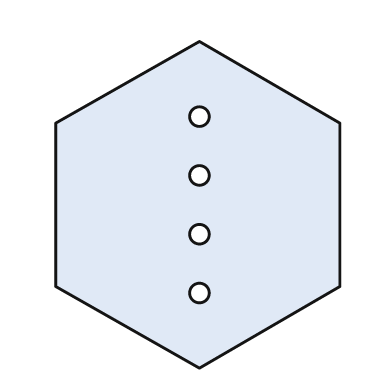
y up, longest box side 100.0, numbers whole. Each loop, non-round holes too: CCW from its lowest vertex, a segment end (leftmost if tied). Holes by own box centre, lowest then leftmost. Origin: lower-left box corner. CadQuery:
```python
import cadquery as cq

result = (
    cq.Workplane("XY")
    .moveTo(44.0, 0.0)
    .lineTo(87.0, 25.0)
    .lineTo(87.0, 75.0)
    .lineTo(44.0, 100.0)
    .lineTo(0.0, 75.0)
    .lineTo(0.0, 25.0)
    .close()
    .moveTo(44.0, 23.0)
    .circle(3.0)
    .moveTo(44.0, 41.0)
    .circle(3.0)
    .moveTo(44.0, 59.0)
    .circle(3.0)
    .moveTo(44.0, 77.0)
    .circle(3.0)
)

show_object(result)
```